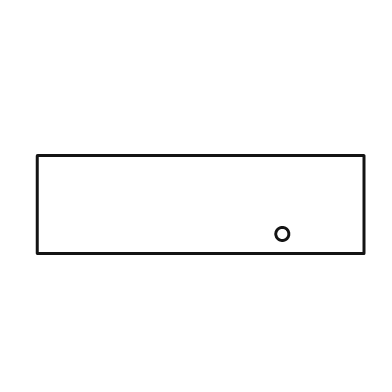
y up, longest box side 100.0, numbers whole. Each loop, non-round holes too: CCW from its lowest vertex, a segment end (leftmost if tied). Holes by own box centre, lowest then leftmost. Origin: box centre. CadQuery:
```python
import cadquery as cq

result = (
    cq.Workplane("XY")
    .moveTo(-50.0, -15.0)
    .lineTo(50.0, -15.0)
    .lineTo(50.0, 15.0)
    .lineTo(-50.0, 15.0)
    .close()
    .moveTo(25.0, -9.0)
    .circle(2.0)
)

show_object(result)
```